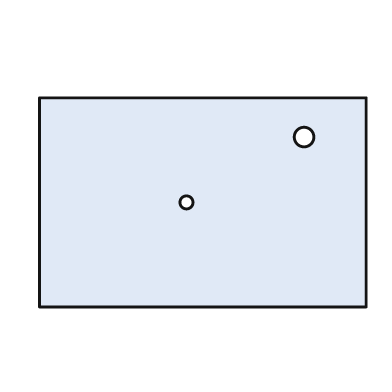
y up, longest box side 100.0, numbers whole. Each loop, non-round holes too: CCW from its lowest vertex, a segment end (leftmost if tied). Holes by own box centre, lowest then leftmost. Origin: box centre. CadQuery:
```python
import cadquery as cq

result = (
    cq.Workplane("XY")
    .moveTo(-50.0, -32.0)
    .lineTo(50.0, -32.0)
    .lineTo(50.0, 32.0)
    .lineTo(-50.0, 32.0)
    .close()
    .moveTo(-5.0, 0.0)
    .circle(2.0)
    .moveTo(31.0, 20.0)
    .circle(3.0)
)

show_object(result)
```